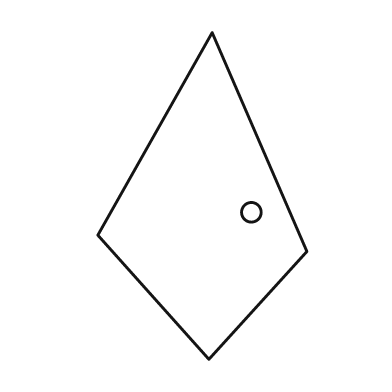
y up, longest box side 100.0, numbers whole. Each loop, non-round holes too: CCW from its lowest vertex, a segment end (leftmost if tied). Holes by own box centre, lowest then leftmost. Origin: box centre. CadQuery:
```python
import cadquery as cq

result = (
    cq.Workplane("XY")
    .moveTo(2.0, -50.0)
    .lineTo(32.0, -17.0)
    .lineTo(3.0, 50.0)
    .lineTo(-32.0, -12.0)
    .close()
    .moveTo(15.0, -5.0)
    .circle(3.0)
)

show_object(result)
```